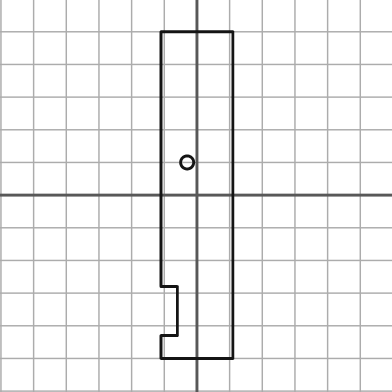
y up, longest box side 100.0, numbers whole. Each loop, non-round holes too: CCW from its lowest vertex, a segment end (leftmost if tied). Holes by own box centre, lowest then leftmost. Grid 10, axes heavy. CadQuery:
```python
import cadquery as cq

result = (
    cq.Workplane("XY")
    .moveTo(-11.0, -50.0)
    .lineTo(11.0, -50.0)
    .lineTo(11.0, 50.0)
    .lineTo(-11.0, 50.0)
    .lineTo(-11.0, -28.0)
    .lineTo(-6.0, -28.0)
    .lineTo(-6.0, -43.0)
    .lineTo(-11.0, -43.0)
    .close()
    .moveTo(-3.0, 10.0)
    .circle(2.0)
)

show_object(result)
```